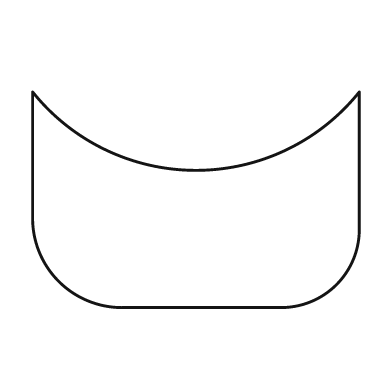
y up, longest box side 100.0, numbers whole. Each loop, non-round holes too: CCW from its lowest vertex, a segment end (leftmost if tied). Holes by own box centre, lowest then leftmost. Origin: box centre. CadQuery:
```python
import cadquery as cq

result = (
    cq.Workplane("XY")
    .moveTo(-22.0, -33.0)
    .lineTo(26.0, -33.0)
    .threePointArc((43.0, -26.0), (50.0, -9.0))
    .lineTo(50.0, 33.0)
    .threePointArc((0.0, 9.0), (-50.0, 33.0))
    .lineTo(-50.0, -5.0)
    .threePointArc((-42.0, -25.0), (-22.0, -33.0))
    .close()
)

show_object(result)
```